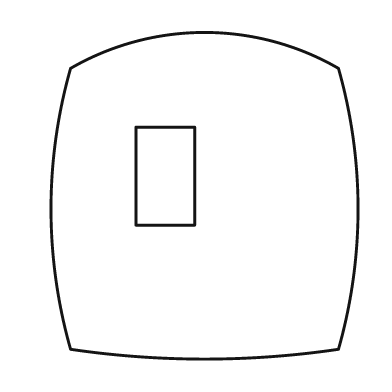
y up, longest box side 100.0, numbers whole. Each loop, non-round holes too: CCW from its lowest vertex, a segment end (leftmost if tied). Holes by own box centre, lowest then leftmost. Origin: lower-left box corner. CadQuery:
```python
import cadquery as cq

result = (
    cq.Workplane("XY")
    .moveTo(6.0, 3.0)
    .threePointArc((47.0, 0.0), (88.0, 3.0))
    .threePointArc((94.0, 46.0), (88.0, 89.0))
    .threePointArc((47.0, 100.0), (6.0, 89.0))
    .threePointArc((0.0, 46.0), (6.0, 3.0))
    .close()
    .moveTo(26.0, 41.0)
    .lineTo(44.0, 41.0)
    .lineTo(44.0, 71.0)
    .lineTo(26.0, 71.0)
    .close()
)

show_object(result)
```